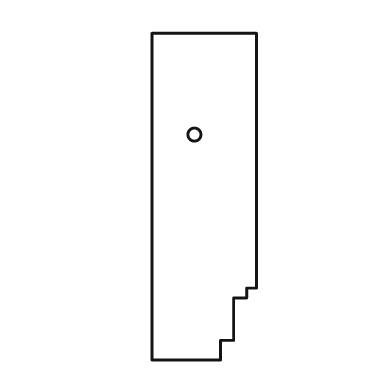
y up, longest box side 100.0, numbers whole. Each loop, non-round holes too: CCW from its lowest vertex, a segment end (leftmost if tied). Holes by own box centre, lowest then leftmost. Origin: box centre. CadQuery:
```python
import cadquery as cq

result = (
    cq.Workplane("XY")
    .moveTo(-16.0, -50.0)
    .lineTo(5.0, -50.0)
    .lineTo(5.0, -44.0)
    .lineTo(9.0, -44.0)
    .lineTo(9.0, -31.0)
    .lineTo(13.0, -31.0)
    .lineTo(13.0, -28.0)
    .lineTo(16.0, -28.0)
    .lineTo(16.0, 50.0)
    .lineTo(-16.0, 50.0)
    .close()
    .moveTo(-3.0, 19.0)
    .circle(2.0)
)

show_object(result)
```